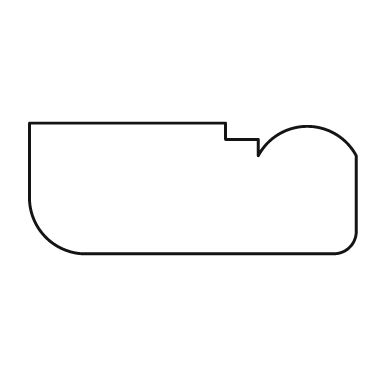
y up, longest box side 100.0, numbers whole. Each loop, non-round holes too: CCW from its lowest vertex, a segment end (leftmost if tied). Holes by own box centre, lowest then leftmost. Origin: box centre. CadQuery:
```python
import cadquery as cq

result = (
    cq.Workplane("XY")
    .moveTo(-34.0, -20.0)
    .lineTo(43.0, -20.0)
    .threePointArc((48.0, -18.0), (50.0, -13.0))
    .lineTo(50.0, 10.0)
    .threePointArc((35.0, 19.0), (20.0, 10.0))
    .lineTo(20.0, 15.0)
    .lineTo(10.0, 15.0)
    .lineTo(10.0, 20.0)
    .lineTo(-50.0, 20.0)
    .lineTo(-50.0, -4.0)
    .threePointArc((-45.0, -15.0), (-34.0, -20.0))
    .close()
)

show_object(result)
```